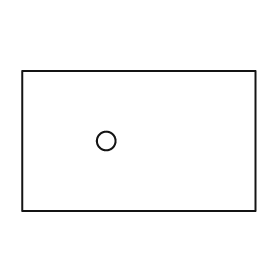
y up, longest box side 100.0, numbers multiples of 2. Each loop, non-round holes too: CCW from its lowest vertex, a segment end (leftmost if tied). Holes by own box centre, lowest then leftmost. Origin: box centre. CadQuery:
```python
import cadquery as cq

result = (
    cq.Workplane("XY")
    .moveTo(-50.0, -30.0)
    .lineTo(50.0, -30.0)
    .lineTo(50.0, 30.0)
    .lineTo(-50.0, 30.0)
    .close()
    .moveTo(-14.0, 0.0)
    .circle(4.0)
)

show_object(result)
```